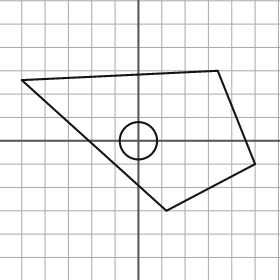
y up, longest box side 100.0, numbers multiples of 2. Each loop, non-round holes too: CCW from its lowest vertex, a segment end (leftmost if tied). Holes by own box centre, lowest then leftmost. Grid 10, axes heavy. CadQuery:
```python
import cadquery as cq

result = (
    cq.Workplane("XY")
    .moveTo(12.0, -30.0)
    .lineTo(50.0, -10.0)
    .lineTo(34.0, 30.0)
    .lineTo(-50.0, 26.0)
    .close()
    .moveTo(0.0, 0.0)
    .circle(8.0)
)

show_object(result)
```